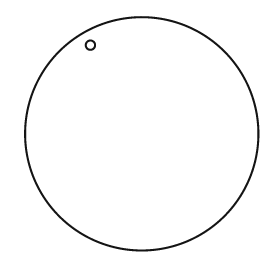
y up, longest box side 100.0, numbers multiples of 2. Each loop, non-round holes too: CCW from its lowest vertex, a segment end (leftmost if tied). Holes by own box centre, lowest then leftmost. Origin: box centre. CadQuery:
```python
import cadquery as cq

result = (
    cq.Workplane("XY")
    .moveTo(0.0, 0.0)
    .circle(50.0)
    .moveTo(-22.0, 38.0)
    .circle(2.0)
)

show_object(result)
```